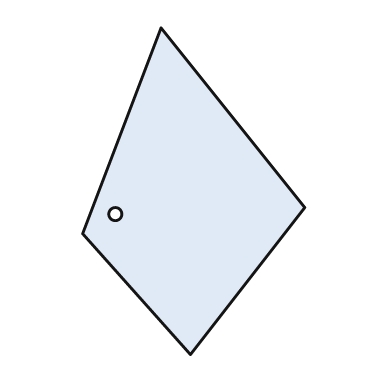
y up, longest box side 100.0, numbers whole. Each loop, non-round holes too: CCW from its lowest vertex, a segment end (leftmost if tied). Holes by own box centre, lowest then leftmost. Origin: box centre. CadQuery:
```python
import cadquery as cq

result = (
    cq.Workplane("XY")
    .moveTo(-1.0, -50.0)
    .lineTo(34.0, -5.0)
    .lineTo(-10.0, 50.0)
    .lineTo(-34.0, -13.0)
    .close()
    .moveTo(-24.0, -7.0)
    .circle(2.0)
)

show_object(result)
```